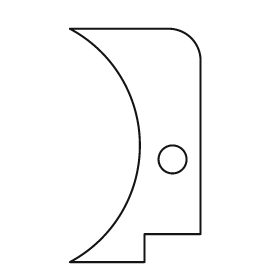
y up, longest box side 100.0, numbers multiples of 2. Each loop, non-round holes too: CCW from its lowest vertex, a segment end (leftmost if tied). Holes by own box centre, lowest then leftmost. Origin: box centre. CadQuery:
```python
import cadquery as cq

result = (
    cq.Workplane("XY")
    .moveTo(-28.0, -50.0)
    .lineTo(4.0, -50.0)
    .lineTo(4.0, -38.0)
    .lineTo(28.0, -38.0)
    .lineTo(28.0, 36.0)
    .threePointArc((24.0, 46.0), (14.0, 50.0))
    .lineTo(-28.0, 50.0)
    .threePointArc((2.0, 0.0), (-28.0, -50.0))
    .close()
    .moveTo(16.0, -6.0)
    .circle(6.0)
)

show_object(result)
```